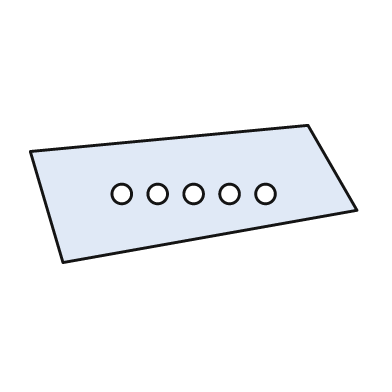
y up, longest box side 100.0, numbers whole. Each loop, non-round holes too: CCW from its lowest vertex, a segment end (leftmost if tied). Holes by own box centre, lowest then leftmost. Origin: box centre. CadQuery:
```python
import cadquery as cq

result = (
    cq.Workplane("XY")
    .moveTo(-40.0, -21.0)
    .lineTo(50.0, -5.0)
    .lineTo(35.0, 21.0)
    .lineTo(-50.0, 13.0)
    .close()
    .moveTo(-22.0, 0.0)
    .circle(3.0)
    .moveTo(-11.0, 0.0)
    .circle(3.0)
    .moveTo(0.0, 0.0)
    .circle(3.0)
    .moveTo(11.0, 0.0)
    .circle(3.0)
    .moveTo(22.0, 0.0)
    .circle(3.0)
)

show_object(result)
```